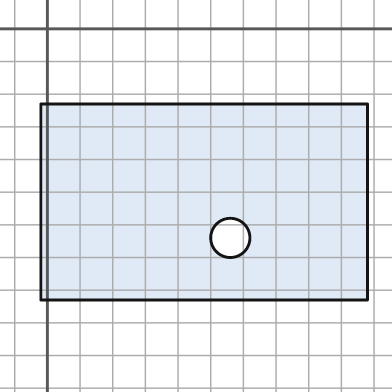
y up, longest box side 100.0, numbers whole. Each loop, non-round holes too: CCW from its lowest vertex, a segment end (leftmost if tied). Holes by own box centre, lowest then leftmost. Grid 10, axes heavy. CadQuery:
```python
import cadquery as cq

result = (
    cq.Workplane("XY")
    .moveTo(-2.0, -83.0)
    .lineTo(98.0, -83.0)
    .lineTo(98.0, -23.0)
    .lineTo(-2.0, -23.0)
    .close()
    .moveTo(56.0, -64.0)
    .circle(6.0)
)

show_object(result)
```